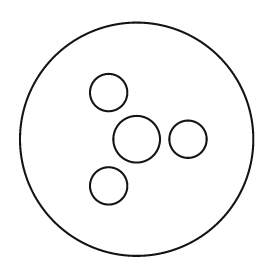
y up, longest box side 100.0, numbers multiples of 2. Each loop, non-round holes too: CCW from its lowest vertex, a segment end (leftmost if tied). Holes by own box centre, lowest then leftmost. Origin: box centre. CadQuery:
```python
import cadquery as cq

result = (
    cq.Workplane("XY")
    .moveTo(0.0, 0.0)
    .circle(50.0)
    .moveTo(-12.0, -20.0)
    .circle(8.0)
    .moveTo(0.0, 0.0)
    .circle(10.0)
    .moveTo(22.0, 0.0)
    .circle(8.0)
    .moveTo(-12.0, 20.0)
    .circle(8.0)
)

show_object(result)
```